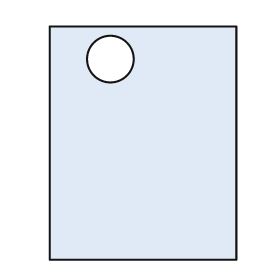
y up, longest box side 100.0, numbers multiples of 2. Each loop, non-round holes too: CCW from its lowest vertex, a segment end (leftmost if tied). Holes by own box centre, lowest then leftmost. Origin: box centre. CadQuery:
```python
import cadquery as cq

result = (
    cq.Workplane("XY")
    .moveTo(-40.0, -50.0)
    .lineTo(40.0, -50.0)
    .lineTo(40.0, 50.0)
    .lineTo(-40.0, 50.0)
    .close()
    .moveTo(-14.0, 36.0)
    .circle(10.0)
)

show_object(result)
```